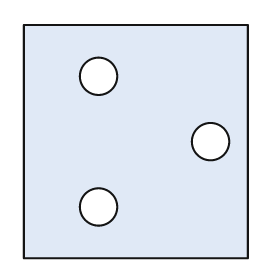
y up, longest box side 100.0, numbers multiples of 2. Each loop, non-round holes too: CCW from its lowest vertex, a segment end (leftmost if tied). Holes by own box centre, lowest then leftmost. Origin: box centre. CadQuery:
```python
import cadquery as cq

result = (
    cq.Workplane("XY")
    .moveTo(-48.0, -50.0)
    .lineTo(48.0, -50.0)
    .lineTo(48.0, 50.0)
    .lineTo(-48.0, 50.0)
    .close()
    .moveTo(-16.0, -28.0)
    .circle(8.0)
    .moveTo(32.0, 0.0)
    .circle(8.0)
    .moveTo(-16.0, 28.0)
    .circle(8.0)
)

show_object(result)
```